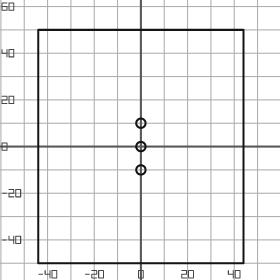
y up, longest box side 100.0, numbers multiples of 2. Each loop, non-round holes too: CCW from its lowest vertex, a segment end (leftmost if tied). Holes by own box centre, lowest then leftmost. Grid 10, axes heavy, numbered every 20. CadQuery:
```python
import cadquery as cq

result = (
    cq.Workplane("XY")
    .moveTo(-44.0, -50.0)
    .lineTo(44.0, -50.0)
    .lineTo(44.0, 50.0)
    .lineTo(-44.0, 50.0)
    .close()
    .moveTo(0.0, -10.0)
    .circle(2.0)
    .moveTo(0.0, 0.0)
    .circle(2.0)
    .moveTo(0.0, 10.0)
    .circle(2.0)
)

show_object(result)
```